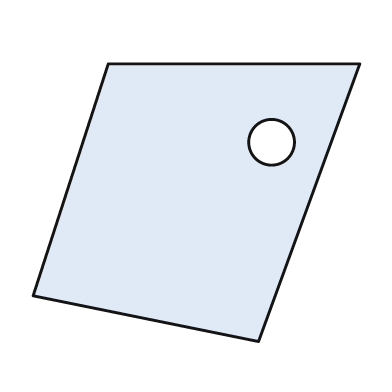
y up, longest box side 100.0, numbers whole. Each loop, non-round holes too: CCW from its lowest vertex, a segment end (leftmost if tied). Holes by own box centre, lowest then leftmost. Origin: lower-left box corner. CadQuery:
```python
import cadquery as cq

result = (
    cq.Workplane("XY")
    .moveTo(69.0, 0.0)
    .lineTo(100.0, 85.0)
    .lineTo(23.0, 85.0)
    .lineTo(0.0, 14.0)
    .close()
    .moveTo(73.0, 61.0)
    .circle(7.0)
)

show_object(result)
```